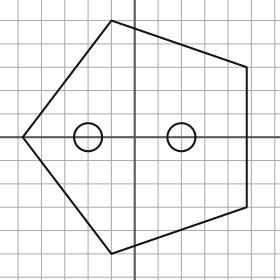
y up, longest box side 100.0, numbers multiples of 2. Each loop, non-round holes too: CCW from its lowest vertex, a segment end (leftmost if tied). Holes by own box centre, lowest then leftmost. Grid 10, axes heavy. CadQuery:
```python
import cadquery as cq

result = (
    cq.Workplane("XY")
    .moveTo(-10.0, -50.0)
    .lineTo(48.0, -30.0)
    .lineTo(48.0, 30.0)
    .lineTo(-10.0, 50.0)
    .lineTo(-48.0, 0.0)
    .close()
    .moveTo(-20.0, 0.0)
    .circle(6.0)
    .moveTo(20.0, 0.0)
    .circle(6.0)
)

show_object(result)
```